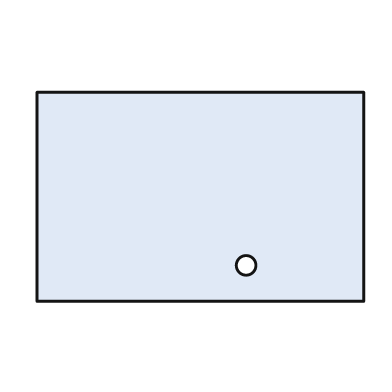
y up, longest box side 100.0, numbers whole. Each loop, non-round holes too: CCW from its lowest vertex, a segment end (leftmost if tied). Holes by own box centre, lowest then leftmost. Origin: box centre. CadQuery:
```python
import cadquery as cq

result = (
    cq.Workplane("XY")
    .moveTo(-50.0, -32.0)
    .lineTo(50.0, -32.0)
    .lineTo(50.0, 32.0)
    .lineTo(-50.0, 32.0)
    .close()
    .moveTo(14.0, -21.0)
    .circle(3.0)
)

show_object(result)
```